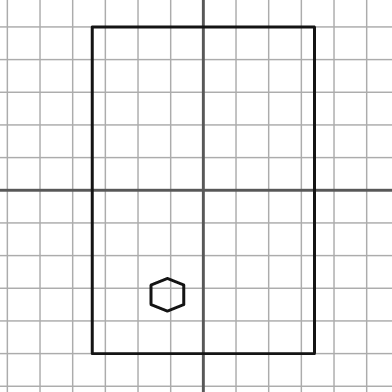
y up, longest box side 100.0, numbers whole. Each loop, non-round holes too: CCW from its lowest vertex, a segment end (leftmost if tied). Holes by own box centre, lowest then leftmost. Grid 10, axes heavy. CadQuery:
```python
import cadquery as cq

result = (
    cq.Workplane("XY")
    .moveTo(-34.0, -50.0)
    .lineTo(34.0, -50.0)
    .lineTo(34.0, 50.0)
    .lineTo(-34.0, 50.0)
    .close()
    .moveTo(-11.0, -37.0)
    .lineTo(-6.0, -35.0)
    .lineTo(-6.0, -29.0)
    .lineTo(-11.0, -27.0)
    .lineTo(-16.0, -29.0)
    .lineTo(-16.0, -35.0)
    .close()
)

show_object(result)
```